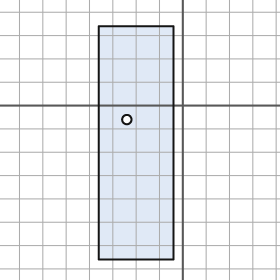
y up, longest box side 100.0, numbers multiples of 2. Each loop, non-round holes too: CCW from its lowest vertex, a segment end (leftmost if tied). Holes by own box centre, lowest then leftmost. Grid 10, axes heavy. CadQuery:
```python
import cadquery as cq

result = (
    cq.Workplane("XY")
    .moveTo(-36.0, -66.0)
    .lineTo(-4.0, -66.0)
    .lineTo(-4.0, 34.0)
    .lineTo(-36.0, 34.0)
    .close()
    .moveTo(-24.0, -6.0)
    .circle(2.0)
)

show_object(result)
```